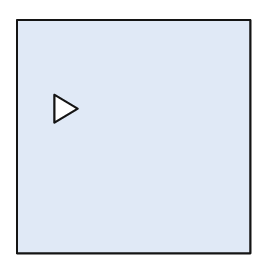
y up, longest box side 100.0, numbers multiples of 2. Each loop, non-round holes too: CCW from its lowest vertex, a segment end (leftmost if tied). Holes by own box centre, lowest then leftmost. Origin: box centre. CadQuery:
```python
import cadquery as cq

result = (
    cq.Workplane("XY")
    .moveTo(-50.0, -50.0)
    .lineTo(50.0, -50.0)
    .lineTo(50.0, 50.0)
    .lineTo(-50.0, 50.0)
    .close()
    .moveTo(-34.0, 6.0)
    .lineTo(-24.0, 12.0)
    .lineTo(-34.0, 18.0)
    .close()
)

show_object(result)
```